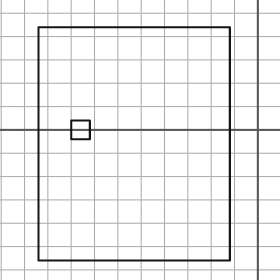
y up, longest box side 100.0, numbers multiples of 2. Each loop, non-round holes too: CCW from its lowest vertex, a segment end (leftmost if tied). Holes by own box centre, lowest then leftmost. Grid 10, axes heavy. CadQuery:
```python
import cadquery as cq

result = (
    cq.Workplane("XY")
    .moveTo(-94.0, -56.0)
    .lineTo(-12.0, -56.0)
    .lineTo(-12.0, 44.0)
    .lineTo(-94.0, 44.0)
    .close()
    .moveTo(-80.0, -4.0)
    .lineTo(-72.0, -4.0)
    .lineTo(-72.0, 4.0)
    .lineTo(-80.0, 4.0)
    .close()
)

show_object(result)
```